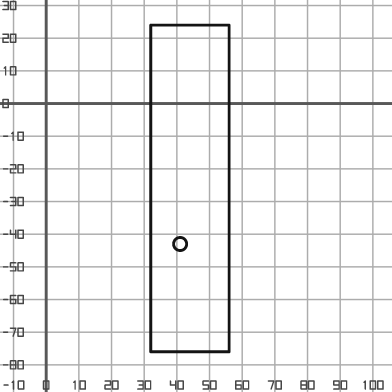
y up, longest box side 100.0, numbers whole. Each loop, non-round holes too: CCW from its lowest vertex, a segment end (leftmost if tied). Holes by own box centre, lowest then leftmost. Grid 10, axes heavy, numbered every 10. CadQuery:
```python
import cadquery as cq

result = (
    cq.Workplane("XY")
    .moveTo(32.0, -76.0)
    .lineTo(56.0, -76.0)
    .lineTo(56.0, 24.0)
    .lineTo(32.0, 24.0)
    .close()
    .moveTo(41.0, -43.0)
    .circle(2.0)
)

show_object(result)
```